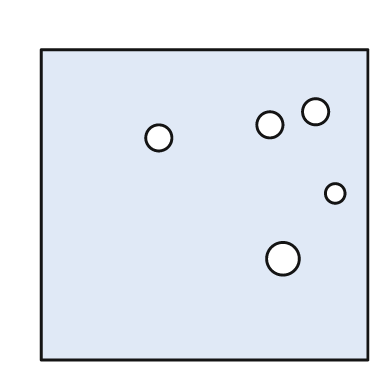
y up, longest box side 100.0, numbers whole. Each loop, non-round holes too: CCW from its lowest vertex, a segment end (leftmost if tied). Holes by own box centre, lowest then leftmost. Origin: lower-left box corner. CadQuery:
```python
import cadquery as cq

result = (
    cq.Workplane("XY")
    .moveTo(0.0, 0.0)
    .lineTo(100.0, 0.0)
    .lineTo(100.0, 95.0)
    .lineTo(0.0, 95.0)
    .close()
    .moveTo(74.0, 31.0)
    .circle(5.0)
    .moveTo(90.0, 51.0)
    .circle(3.0)
    .moveTo(36.0, 68.0)
    .circle(4.0)
    .moveTo(70.0, 72.0)
    .circle(4.0)
    .moveTo(84.0, 76.0)
    .circle(4.0)
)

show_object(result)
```